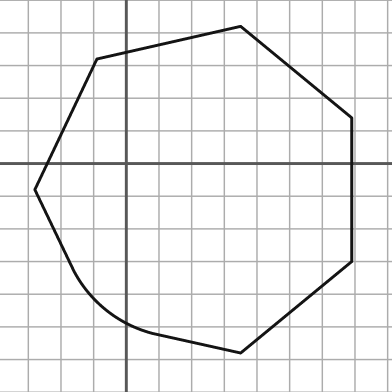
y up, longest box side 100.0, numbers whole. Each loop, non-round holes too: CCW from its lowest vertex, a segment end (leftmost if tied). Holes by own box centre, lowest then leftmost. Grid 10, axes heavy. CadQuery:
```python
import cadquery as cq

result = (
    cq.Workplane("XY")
    .moveTo(35.0, -58.0)
    .lineTo(69.0, -30.0)
    .lineTo(69.0, 14.0)
    .lineTo(35.0, 42.0)
    .lineTo(-9.0, 32.0)
    .lineTo(-28.0, -8.0)
    .lineTo(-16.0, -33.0)
    .threePointArc((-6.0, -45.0), (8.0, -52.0))
    .close()
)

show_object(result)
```